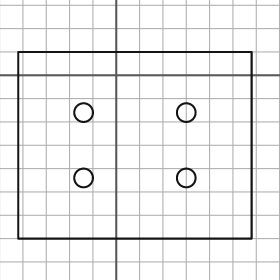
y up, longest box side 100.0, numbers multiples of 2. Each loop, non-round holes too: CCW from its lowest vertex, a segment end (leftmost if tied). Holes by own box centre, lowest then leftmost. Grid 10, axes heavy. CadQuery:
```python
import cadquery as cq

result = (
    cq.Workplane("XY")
    .moveTo(-42.0, -70.0)
    .lineTo(58.0, -70.0)
    .lineTo(58.0, 10.0)
    .lineTo(-42.0, 10.0)
    .close()
    .moveTo(-14.0, -44.0)
    .circle(4.0)
    .moveTo(30.0, -44.0)
    .circle(4.0)
    .moveTo(-14.0, -16.0)
    .circle(4.0)
    .moveTo(30.0, -16.0)
    .circle(4.0)
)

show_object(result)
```